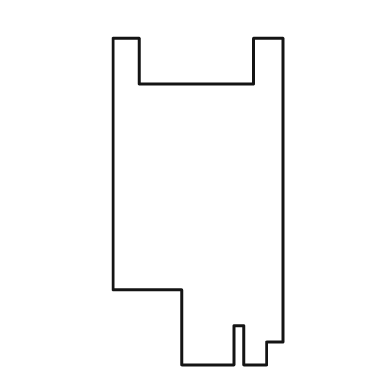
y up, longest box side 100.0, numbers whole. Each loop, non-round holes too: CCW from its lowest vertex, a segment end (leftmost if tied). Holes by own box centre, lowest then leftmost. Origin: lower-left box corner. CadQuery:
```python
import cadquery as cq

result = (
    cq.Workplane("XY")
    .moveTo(21.0, 0.0)
    .lineTo(37.0, 0.0)
    .lineTo(37.0, 12.0)
    .lineTo(40.0, 12.0)
    .lineTo(40.0, 0.0)
    .lineTo(47.0, 0.0)
    .lineTo(47.0, 7.0)
    .lineTo(52.0, 7.0)
    .lineTo(52.0, 100.0)
    .lineTo(43.0, 100.0)
    .lineTo(43.0, 86.0)
    .lineTo(8.0, 86.0)
    .lineTo(8.0, 100.0)
    .lineTo(0.0, 100.0)
    .lineTo(0.0, 23.0)
    .lineTo(21.0, 23.0)
    .close()
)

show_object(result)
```